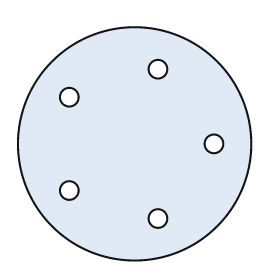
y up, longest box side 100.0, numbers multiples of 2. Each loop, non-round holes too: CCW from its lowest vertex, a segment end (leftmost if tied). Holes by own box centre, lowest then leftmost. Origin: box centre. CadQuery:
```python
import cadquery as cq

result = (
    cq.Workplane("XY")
    .moveTo(0.0, 0.0)
    .circle(50.0)
    .moveTo(10.0, -32.0)
    .circle(4.0)
    .moveTo(-28.0, -20.0)
    .circle(4.0)
    .moveTo(34.0, 0.0)
    .circle(4.0)
    .moveTo(-28.0, 20.0)
    .circle(4.0)
    .moveTo(10.0, 32.0)
    .circle(4.0)
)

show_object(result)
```